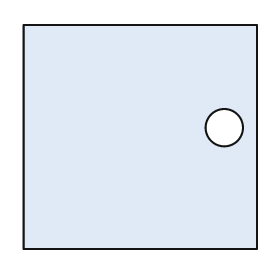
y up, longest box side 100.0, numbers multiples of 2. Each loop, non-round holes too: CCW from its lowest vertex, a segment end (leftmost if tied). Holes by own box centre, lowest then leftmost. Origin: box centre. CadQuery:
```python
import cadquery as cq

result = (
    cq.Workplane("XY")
    .moveTo(-50.0, -48.0)
    .lineTo(50.0, -48.0)
    .lineTo(50.0, 48.0)
    .lineTo(-50.0, 48.0)
    .close()
    .moveTo(36.0, 4.0)
    .circle(8.0)
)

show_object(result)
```